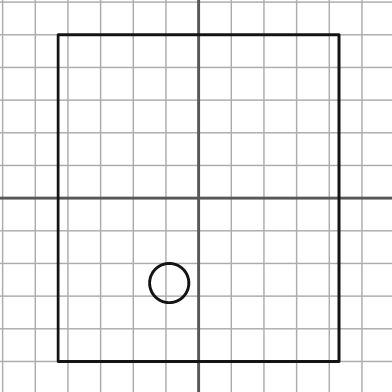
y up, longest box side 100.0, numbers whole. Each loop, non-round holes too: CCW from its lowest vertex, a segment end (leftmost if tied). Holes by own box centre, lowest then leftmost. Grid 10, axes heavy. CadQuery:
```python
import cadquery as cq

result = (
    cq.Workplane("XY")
    .moveTo(-43.0, -50.0)
    .lineTo(43.0, -50.0)
    .lineTo(43.0, 50.0)
    .lineTo(-43.0, 50.0)
    .close()
    .moveTo(-9.0, -26.0)
    .circle(6.0)
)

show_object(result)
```